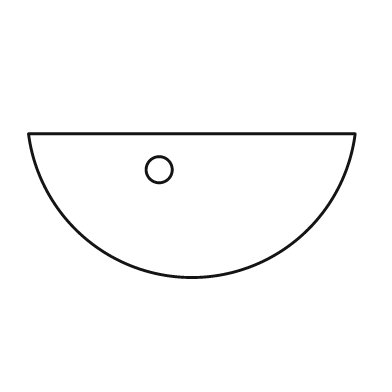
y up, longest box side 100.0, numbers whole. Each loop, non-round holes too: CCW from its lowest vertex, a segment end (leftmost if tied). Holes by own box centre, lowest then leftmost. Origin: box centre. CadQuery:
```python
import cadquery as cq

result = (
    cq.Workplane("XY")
    .moveTo(-50.0, 22.0)
    .threePointArc((0.0, -22.0), (50.0, 22.0))
    .close()
    .moveTo(-10.0, 11.0)
    .circle(4.0)
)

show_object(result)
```